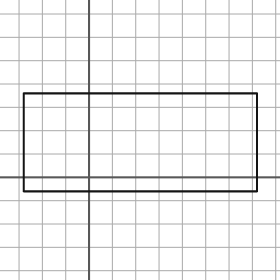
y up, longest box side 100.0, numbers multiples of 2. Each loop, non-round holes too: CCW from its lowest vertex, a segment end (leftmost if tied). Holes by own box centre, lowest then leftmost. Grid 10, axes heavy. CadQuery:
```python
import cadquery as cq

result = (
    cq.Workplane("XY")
    .moveTo(-28.0, -6.0)
    .lineTo(72.0, -6.0)
    .lineTo(72.0, 36.0)
    .lineTo(-28.0, 36.0)
    .close()
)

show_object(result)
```